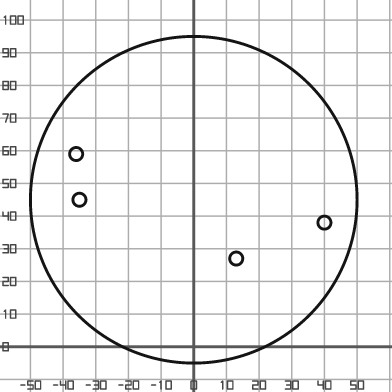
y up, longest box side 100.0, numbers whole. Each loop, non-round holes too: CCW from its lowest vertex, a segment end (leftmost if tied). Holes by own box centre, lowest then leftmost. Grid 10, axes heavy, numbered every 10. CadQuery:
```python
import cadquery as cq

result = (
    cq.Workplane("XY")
    .moveTo(0.0, 45.0)
    .circle(50.0)
    .moveTo(13.0, 27.0)
    .circle(2.0)
    .moveTo(40.0, 38.0)
    .circle(2.0)
    .moveTo(-35.0, 45.0)
    .circle(2.0)
    .moveTo(-36.0, 59.0)
    .circle(2.0)
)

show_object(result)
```